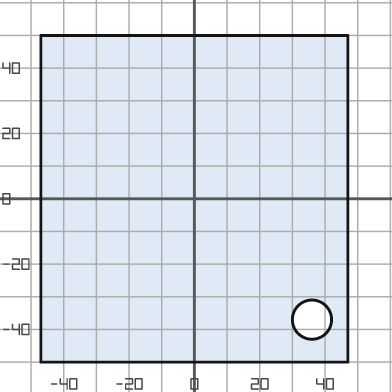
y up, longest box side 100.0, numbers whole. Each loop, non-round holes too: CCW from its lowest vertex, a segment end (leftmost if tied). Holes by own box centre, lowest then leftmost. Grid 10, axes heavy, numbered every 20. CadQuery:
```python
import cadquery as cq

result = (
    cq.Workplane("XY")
    .moveTo(-47.0, -50.0)
    .lineTo(47.0, -50.0)
    .lineTo(47.0, 50.0)
    .lineTo(-47.0, 50.0)
    .close()
    .moveTo(36.0, -37.0)
    .circle(6.0)
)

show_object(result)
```